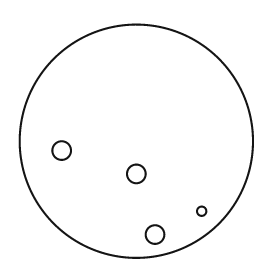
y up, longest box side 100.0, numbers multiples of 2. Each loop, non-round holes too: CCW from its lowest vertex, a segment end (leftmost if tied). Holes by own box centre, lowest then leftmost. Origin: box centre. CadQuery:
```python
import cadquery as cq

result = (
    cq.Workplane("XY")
    .moveTo(0.0, 0.0)
    .circle(50.0)
    .moveTo(8.0, -40.0)
    .circle(4.0)
    .moveTo(28.0, -30.0)
    .circle(2.0)
    .moveTo(0.0, -14.0)
    .circle(4.0)
    .moveTo(-32.0, -4.0)
    .circle(4.0)
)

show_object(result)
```